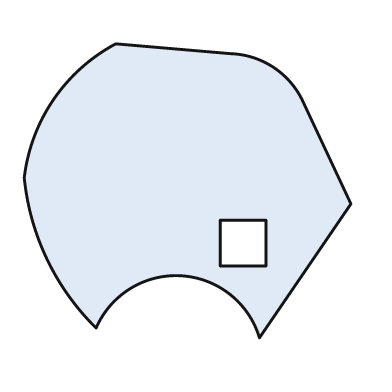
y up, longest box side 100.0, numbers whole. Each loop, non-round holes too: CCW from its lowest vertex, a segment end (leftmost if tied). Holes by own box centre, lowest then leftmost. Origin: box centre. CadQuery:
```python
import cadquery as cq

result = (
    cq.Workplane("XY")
    .moveTo(22.0, -45.0)
    .lineTo(50.0, -4.0)
    .lineTo(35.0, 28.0)
    .threePointArc((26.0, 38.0), (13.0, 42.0))
    .lineTo(-22.0, 45.0)
    .threePointArc((-41.0, 28.0), (-50.0, 4.0))
    .threePointArc((-43.0, -21.0), (-28.0, -42.0))
    .threePointArc((-2.0, -26.0), (22.0, -45.0))
    .close()
    .moveTo(10.0, -23.0)
    .lineTo(24.0, -23.0)
    .lineTo(24.0, -9.0)
    .lineTo(10.0, -9.0)
    .close()
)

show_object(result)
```